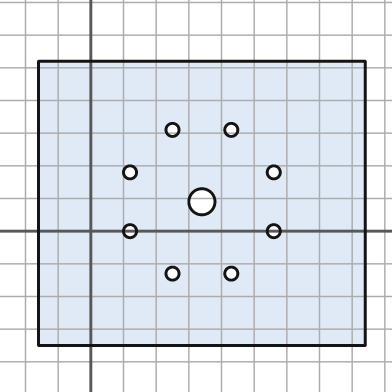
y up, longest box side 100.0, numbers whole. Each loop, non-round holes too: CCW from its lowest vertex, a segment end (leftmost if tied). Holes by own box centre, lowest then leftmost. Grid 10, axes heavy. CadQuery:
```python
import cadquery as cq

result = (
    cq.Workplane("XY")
    .moveTo(-16.0, -35.0)
    .lineTo(84.0, -35.0)
    .lineTo(84.0, 52.0)
    .lineTo(-16.0, 52.0)
    .close()
    .moveTo(25.0, -13.0)
    .circle(2.0)
    .moveTo(43.0, -13.0)
    .circle(2.0)
    .moveTo(12.0, 0.0)
    .circle(2.0)
    .moveTo(56.0, 0.0)
    .circle(2.0)
    .moveTo(34.0, 9.0)
    .circle(4.0)
    .moveTo(12.0, 18.0)
    .circle(2.0)
    .moveTo(56.0, 18.0)
    .circle(2.0)
    .moveTo(25.0, 31.0)
    .circle(2.0)
    .moveTo(43.0, 31.0)
    .circle(2.0)
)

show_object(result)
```